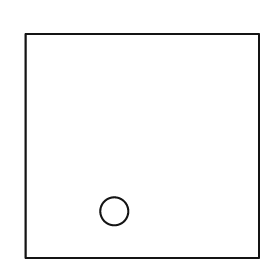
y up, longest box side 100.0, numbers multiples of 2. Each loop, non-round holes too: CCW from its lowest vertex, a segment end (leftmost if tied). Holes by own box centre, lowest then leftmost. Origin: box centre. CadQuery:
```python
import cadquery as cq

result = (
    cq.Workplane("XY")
    .moveTo(-50.0, -48.0)
    .lineTo(50.0, -48.0)
    .lineTo(50.0, 48.0)
    .lineTo(-50.0, 48.0)
    .close()
    .moveTo(-12.0, -28.0)
    .circle(6.0)
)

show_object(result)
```